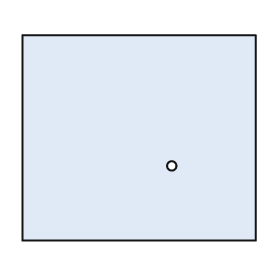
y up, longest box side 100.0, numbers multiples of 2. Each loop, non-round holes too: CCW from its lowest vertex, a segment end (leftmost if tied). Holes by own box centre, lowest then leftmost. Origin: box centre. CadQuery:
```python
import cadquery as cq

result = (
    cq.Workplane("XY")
    .moveTo(-50.0, -44.0)
    .lineTo(50.0, -44.0)
    .lineTo(50.0, 44.0)
    .lineTo(-50.0, 44.0)
    .close()
    .moveTo(14.0, -12.0)
    .circle(2.0)
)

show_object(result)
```